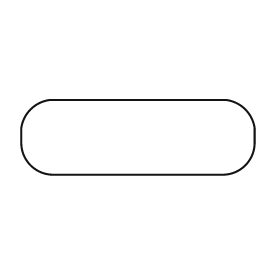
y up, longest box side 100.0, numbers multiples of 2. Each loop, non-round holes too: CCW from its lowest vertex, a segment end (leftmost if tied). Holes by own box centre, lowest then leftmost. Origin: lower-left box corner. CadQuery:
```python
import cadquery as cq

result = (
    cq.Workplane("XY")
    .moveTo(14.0, 0.0)
    .lineTo(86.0, 0.0)
    .threePointArc((96.0, 4.0), (100.0, 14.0))
    .lineTo(100.0, 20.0)
    .threePointArc((96.0, 28.0), (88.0, 32.0))
    .lineTo(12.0, 32.0)
    .threePointArc((4.0, 28.0), (0.0, 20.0))
    .lineTo(0.0, 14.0)
    .threePointArc((4.0, 4.0), (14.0, 0.0))
    .close()
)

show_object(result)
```